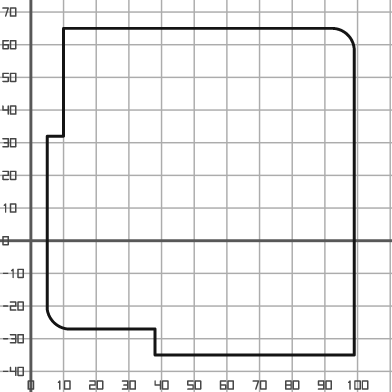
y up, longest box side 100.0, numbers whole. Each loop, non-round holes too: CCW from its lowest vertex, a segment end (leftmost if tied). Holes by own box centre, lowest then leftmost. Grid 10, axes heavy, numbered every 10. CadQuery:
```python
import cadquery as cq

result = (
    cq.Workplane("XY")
    .moveTo(38.0, -35.0)
    .lineTo(99.0, -35.0)
    .lineTo(99.0, 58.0)
    .threePointArc((97.0, 63.0), (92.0, 65.0))
    .lineTo(10.0, 65.0)
    .lineTo(10.0, 32.0)
    .lineTo(5.0, 32.0)
    .lineTo(5.0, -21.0)
    .threePointArc((7.0, -25.0), (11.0, -27.0))
    .lineTo(38.0, -27.0)
    .close()
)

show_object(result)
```